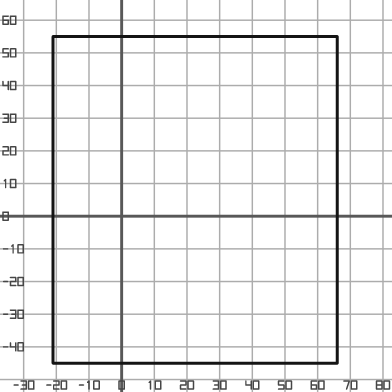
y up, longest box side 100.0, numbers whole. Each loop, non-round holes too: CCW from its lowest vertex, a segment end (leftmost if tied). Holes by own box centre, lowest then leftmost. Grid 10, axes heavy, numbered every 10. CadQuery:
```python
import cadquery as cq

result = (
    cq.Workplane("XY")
    .moveTo(-21.0, -45.0)
    .lineTo(66.0, -45.0)
    .lineTo(66.0, 55.0)
    .lineTo(-21.0, 55.0)
    .close()
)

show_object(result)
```